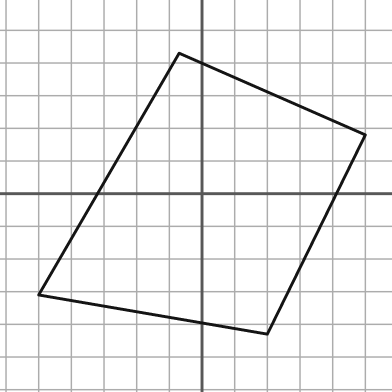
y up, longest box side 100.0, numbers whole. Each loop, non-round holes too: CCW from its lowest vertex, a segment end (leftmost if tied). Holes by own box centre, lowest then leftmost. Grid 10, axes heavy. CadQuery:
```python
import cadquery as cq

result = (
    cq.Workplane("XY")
    .moveTo(20.0, -43.0)
    .lineTo(50.0, 18.0)
    .lineTo(-7.0, 43.0)
    .lineTo(-50.0, -31.0)
    .close()
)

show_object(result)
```